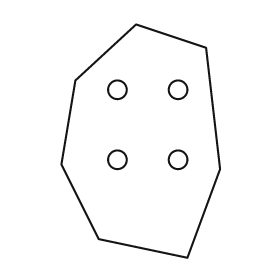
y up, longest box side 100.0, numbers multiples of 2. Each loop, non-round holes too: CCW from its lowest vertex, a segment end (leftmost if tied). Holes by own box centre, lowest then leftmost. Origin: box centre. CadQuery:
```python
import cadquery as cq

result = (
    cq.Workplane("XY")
    .moveTo(20.0, -50.0)
    .lineTo(34.0, -12.0)
    .lineTo(28.0, 40.0)
    .lineTo(-2.0, 50.0)
    .lineTo(-28.0, 26.0)
    .lineTo(-34.0, -10.0)
    .lineTo(-18.0, -42.0)
    .close()
    .moveTo(-10.0, -8.0)
    .circle(4.0)
    .moveTo(16.0, -8.0)
    .circle(4.0)
    .moveTo(-10.0, 22.0)
    .circle(4.0)
    .moveTo(16.0, 22.0)
    .circle(4.0)
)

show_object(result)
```